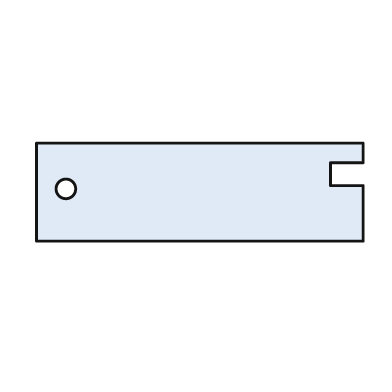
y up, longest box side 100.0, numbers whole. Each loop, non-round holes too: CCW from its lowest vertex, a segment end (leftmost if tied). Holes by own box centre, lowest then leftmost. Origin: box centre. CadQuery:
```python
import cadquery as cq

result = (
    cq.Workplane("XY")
    .moveTo(-50.0, -15.0)
    .lineTo(50.0, -15.0)
    .lineTo(50.0, 2.0)
    .lineTo(40.0, 2.0)
    .lineTo(40.0, 9.0)
    .lineTo(50.0, 9.0)
    .lineTo(50.0, 15.0)
    .lineTo(-50.0, 15.0)
    .close()
    .moveTo(-41.0, 1.0)
    .circle(3.0)
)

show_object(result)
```